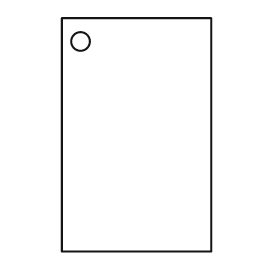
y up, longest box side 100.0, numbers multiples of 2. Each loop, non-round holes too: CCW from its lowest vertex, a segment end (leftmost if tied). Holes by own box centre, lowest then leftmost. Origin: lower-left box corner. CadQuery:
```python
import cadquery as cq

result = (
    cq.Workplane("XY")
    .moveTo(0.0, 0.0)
    .lineTo(64.0, 0.0)
    .lineTo(64.0, 100.0)
    .lineTo(0.0, 100.0)
    .close()
    .moveTo(8.0, 90.0)
    .circle(4.0)
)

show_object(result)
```